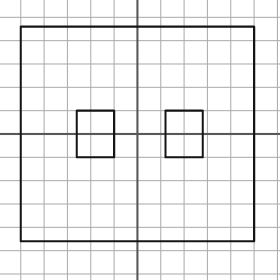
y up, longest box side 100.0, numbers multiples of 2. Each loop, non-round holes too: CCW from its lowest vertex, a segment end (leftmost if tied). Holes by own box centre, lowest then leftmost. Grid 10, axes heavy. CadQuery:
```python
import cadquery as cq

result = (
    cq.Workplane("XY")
    .moveTo(-50.0, -46.0)
    .lineTo(50.0, -46.0)
    .lineTo(50.0, 46.0)
    .lineTo(-50.0, 46.0)
    .close()
    .moveTo(-26.0, -10.0)
    .lineTo(-10.0, -10.0)
    .lineTo(-10.0, 10.0)
    .lineTo(-26.0, 10.0)
    .close()
    .moveTo(12.0, -10.0)
    .lineTo(28.0, -10.0)
    .lineTo(28.0, 10.0)
    .lineTo(12.0, 10.0)
    .close()
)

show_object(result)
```